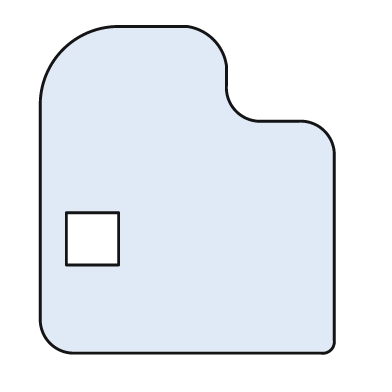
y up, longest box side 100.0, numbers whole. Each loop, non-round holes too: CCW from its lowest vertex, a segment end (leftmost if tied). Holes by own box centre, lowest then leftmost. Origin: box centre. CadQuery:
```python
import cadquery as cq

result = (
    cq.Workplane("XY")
    .moveTo(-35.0, -50.0)
    .lineTo(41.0, -50.0)
    .threePointArc((44.0, -49.0), (45.0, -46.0))
    .lineTo(45.0, 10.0)
    .threePointArc((42.0, 18.0), (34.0, 21.0))
    .lineTo(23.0, 21.0)
    .threePointArc((15.0, 24.0), (12.0, 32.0))
    .lineTo(12.0, 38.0)
    .threePointArc((8.0, 46.0), (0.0, 50.0))
    .lineTo(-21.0, 50.0)
    .threePointArc((-38.0, 43.0), (-45.0, 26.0))
    .lineTo(-45.0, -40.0)
    .threePointArc((-42.0, -47.0), (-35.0, -50.0))
    .close()
    .moveTo(-37.0, -23.0)
    .lineTo(-21.0, -23.0)
    .lineTo(-21.0, -7.0)
    .lineTo(-37.0, -7.0)
    .close()
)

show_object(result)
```